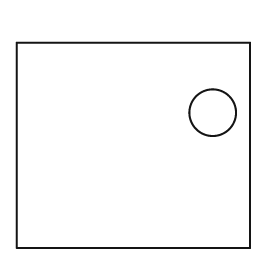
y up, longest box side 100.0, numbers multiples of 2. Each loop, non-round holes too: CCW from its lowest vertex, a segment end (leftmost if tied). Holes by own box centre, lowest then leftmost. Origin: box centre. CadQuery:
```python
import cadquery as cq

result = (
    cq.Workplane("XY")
    .moveTo(-50.0, -44.0)
    .lineTo(50.0, -44.0)
    .lineTo(50.0, 44.0)
    .lineTo(-50.0, 44.0)
    .close()
    .moveTo(34.0, 14.0)
    .circle(10.0)
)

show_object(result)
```